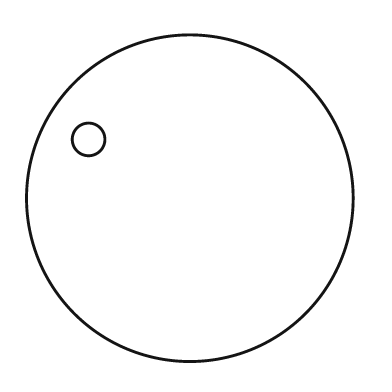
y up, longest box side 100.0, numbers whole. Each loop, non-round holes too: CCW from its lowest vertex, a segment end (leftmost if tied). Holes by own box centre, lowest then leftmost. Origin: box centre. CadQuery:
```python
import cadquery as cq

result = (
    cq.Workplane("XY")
    .moveTo(0.0, 0.0)
    .circle(50.0)
    .moveTo(-31.0, 18.0)
    .circle(5.0)
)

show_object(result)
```